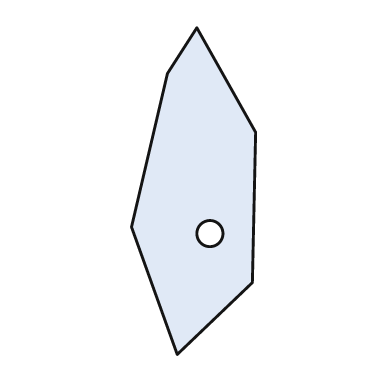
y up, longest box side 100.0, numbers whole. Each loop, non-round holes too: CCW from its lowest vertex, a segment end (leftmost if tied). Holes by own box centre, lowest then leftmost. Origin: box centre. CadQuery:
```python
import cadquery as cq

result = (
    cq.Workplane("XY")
    .moveTo(-5.0, -50.0)
    .lineTo(18.0, -28.0)
    .lineTo(19.0, 18.0)
    .lineTo(1.0, 50.0)
    .lineTo(-8.0, 36.0)
    .lineTo(-19.0, -11.0)
    .close()
    .moveTo(5.0, -13.0)
    .circle(4.0)
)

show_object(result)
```